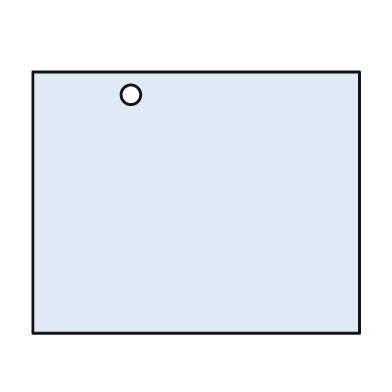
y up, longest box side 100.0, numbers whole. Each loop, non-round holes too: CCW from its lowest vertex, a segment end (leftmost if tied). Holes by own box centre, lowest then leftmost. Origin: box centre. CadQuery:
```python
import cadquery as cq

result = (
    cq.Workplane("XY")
    .moveTo(-50.0, -40.0)
    .lineTo(50.0, -40.0)
    .lineTo(50.0, 40.0)
    .lineTo(-50.0, 40.0)
    .close()
    .moveTo(-20.0, 33.0)
    .circle(3.0)
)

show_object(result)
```